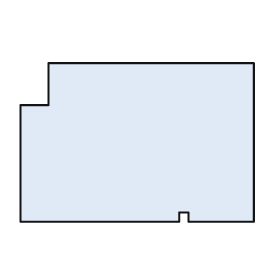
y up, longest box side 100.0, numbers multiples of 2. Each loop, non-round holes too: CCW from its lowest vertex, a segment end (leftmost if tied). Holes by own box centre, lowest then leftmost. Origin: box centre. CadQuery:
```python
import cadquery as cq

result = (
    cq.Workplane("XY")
    .moveTo(-50.0, -34.0)
    .lineTo(18.0, -34.0)
    .lineTo(18.0, -30.0)
    .lineTo(22.0, -30.0)
    .lineTo(22.0, -34.0)
    .lineTo(50.0, -34.0)
    .lineTo(50.0, 34.0)
    .lineTo(-38.0, 34.0)
    .lineTo(-38.0, 16.0)
    .lineTo(-50.0, 16.0)
    .close()
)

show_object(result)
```